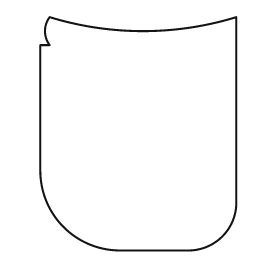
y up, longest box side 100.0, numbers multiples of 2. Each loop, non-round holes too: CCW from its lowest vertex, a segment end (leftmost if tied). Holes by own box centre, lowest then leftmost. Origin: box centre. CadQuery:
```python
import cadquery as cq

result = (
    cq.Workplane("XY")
    .moveTo(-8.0, -50.0)
    .lineTo(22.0, -50.0)
    .threePointArc((36.0, -44.0), (42.0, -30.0))
    .lineTo(42.0, 50.0)
    .threePointArc((2.0, 44.0), (-38.0, 50.0))
    .threePointArc((-40.0, 44.0), (-38.0, 38.0))
    .lineTo(-42.0, 38.0)
    .lineTo(-42.0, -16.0)
    .threePointArc((-32.0, -40.0), (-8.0, -50.0))
    .close()
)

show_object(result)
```